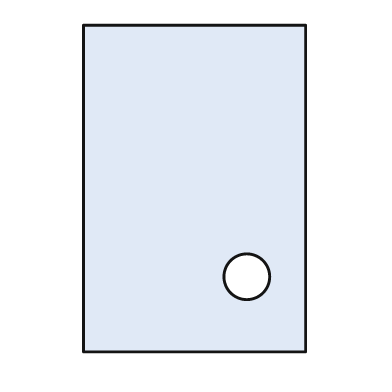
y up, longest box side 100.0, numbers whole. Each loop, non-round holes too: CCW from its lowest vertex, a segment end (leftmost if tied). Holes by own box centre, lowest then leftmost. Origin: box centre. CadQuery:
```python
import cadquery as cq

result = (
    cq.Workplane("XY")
    .moveTo(-34.0, -50.0)
    .lineTo(34.0, -50.0)
    .lineTo(34.0, 50.0)
    .lineTo(-34.0, 50.0)
    .close()
    .moveTo(16.0, -27.0)
    .circle(7.0)
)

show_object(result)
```